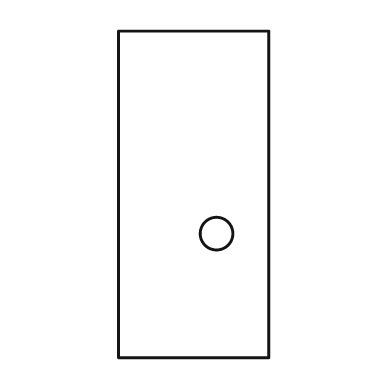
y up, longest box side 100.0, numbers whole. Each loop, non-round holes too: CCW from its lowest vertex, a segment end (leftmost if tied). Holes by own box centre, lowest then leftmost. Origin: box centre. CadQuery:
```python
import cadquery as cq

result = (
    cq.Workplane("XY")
    .moveTo(-23.0, -50.0)
    .lineTo(23.0, -50.0)
    .lineTo(23.0, 50.0)
    .lineTo(-23.0, 50.0)
    .close()
    .moveTo(7.0, -12.0)
    .circle(5.0)
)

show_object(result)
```